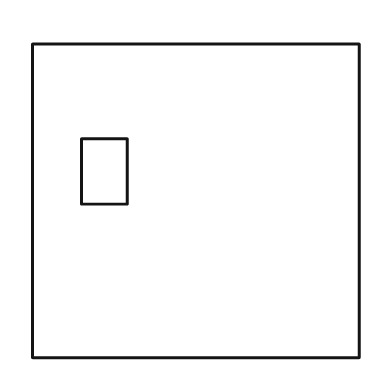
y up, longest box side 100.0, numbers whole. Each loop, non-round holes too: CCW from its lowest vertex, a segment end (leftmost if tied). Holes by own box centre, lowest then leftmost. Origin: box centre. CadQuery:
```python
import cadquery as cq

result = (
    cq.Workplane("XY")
    .moveTo(-50.0, -48.0)
    .lineTo(50.0, -48.0)
    .lineTo(50.0, 48.0)
    .lineTo(-50.0, 48.0)
    .close()
    .moveTo(-35.0, -1.0)
    .lineTo(-21.0, -1.0)
    .lineTo(-21.0, 19.0)
    .lineTo(-35.0, 19.0)
    .close()
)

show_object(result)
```